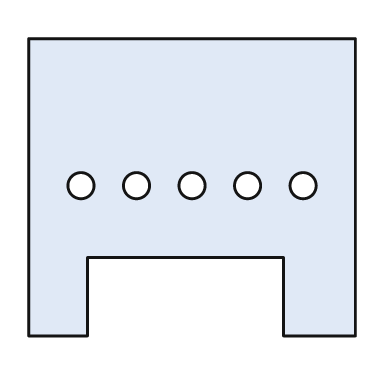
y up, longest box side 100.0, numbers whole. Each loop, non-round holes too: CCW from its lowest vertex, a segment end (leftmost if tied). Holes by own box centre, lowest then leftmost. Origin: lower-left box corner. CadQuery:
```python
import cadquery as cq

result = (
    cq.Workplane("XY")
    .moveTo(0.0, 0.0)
    .lineTo(18.0, 0.0)
    .lineTo(18.0, 24.0)
    .lineTo(78.0, 24.0)
    .lineTo(78.0, 0.0)
    .lineTo(100.0, 0.0)
    .lineTo(100.0, 91.0)
    .lineTo(0.0, 91.0)
    .close()
    .moveTo(16.0, 46.0)
    .circle(4.0)
    .moveTo(33.0, 46.0)
    .circle(4.0)
    .moveTo(50.0, 46.0)
    .circle(4.0)
    .moveTo(67.0, 46.0)
    .circle(4.0)
    .moveTo(84.0, 46.0)
    .circle(4.0)
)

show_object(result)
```